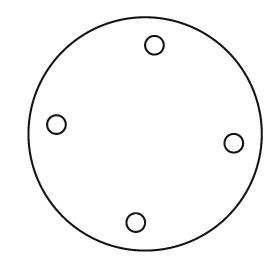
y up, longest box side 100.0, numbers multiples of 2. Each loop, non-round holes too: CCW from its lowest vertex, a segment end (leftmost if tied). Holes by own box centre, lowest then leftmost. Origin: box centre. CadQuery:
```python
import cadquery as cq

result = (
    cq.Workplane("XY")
    .moveTo(0.0, 0.0)
    .circle(50.0)
    .moveTo(-4.0, -38.0)
    .circle(4.0)
    .moveTo(38.0, -4.0)
    .circle(4.0)
    .moveTo(-38.0, 4.0)
    .circle(4.0)
    .moveTo(4.0, 38.0)
    .circle(4.0)
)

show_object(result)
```